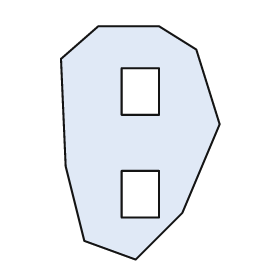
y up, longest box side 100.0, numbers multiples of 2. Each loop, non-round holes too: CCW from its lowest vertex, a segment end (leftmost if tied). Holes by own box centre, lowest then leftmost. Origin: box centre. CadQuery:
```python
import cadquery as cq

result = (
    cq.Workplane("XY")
    .moveTo(-2.0, -50.0)
    .lineTo(18.0, -30.0)
    .lineTo(34.0, 8.0)
    .lineTo(24.0, 40.0)
    .lineTo(8.0, 50.0)
    .lineTo(-18.0, 50.0)
    .lineTo(-34.0, 36.0)
    .lineTo(-32.0, -10.0)
    .lineTo(-24.0, -42.0)
    .close()
    .moveTo(-8.0, -32.0)
    .lineTo(8.0, -32.0)
    .lineTo(8.0, -12.0)
    .lineTo(-8.0, -12.0)
    .close()
    .moveTo(-8.0, 12.0)
    .lineTo(8.0, 12.0)
    .lineTo(8.0, 32.0)
    .lineTo(-8.0, 32.0)
    .close()
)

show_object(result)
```